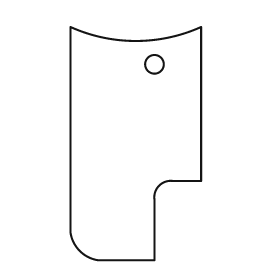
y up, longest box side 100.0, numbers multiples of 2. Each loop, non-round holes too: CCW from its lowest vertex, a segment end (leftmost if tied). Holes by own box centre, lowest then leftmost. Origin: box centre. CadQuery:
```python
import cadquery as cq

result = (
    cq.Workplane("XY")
    .moveTo(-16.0, -50.0)
    .lineTo(8.0, -50.0)
    .lineTo(8.0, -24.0)
    .threePointArc((10.0, -18.0), (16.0, -16.0))
    .lineTo(28.0, -16.0)
    .lineTo(28.0, 50.0)
    .threePointArc((0.0, 44.0), (-28.0, 50.0))
    .lineTo(-28.0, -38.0)
    .threePointArc((-24.0, -46.0), (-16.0, -50.0))
    .close()
    .moveTo(8.0, 34.0)
    .circle(4.0)
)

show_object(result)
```